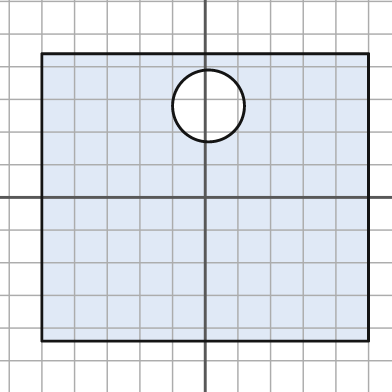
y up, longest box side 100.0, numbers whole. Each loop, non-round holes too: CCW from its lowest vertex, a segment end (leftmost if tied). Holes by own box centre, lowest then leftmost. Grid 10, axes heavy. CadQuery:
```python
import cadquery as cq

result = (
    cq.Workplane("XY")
    .moveTo(-50.0, -44.0)
    .lineTo(50.0, -44.0)
    .lineTo(50.0, 44.0)
    .lineTo(-50.0, 44.0)
    .close()
    .moveTo(1.0, 28.0)
    .circle(11.0)
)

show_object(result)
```